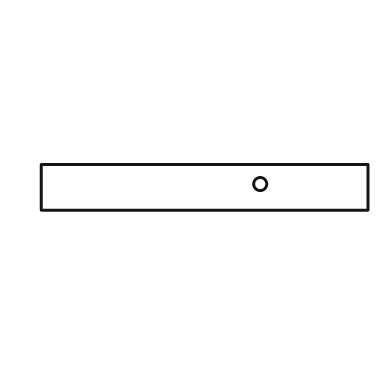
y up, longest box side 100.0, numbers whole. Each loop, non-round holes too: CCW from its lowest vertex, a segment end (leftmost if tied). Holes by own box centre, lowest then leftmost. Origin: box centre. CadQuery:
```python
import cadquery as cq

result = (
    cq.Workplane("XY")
    .moveTo(-50.0, -7.0)
    .lineTo(50.0, -7.0)
    .lineTo(50.0, 7.0)
    .lineTo(-50.0, 7.0)
    .close()
    .moveTo(17.0, 1.0)
    .circle(2.0)
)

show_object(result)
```